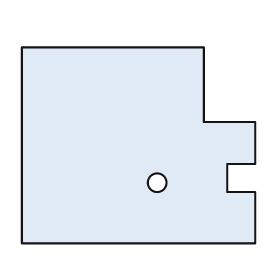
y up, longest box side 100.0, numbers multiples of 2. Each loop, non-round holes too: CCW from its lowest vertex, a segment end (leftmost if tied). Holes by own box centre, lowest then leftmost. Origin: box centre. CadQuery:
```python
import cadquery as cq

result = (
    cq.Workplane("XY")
    .moveTo(-50.0, -42.0)
    .lineTo(50.0, -42.0)
    .lineTo(50.0, -20.0)
    .lineTo(38.0, -20.0)
    .lineTo(38.0, -8.0)
    .lineTo(50.0, -8.0)
    .lineTo(50.0, 10.0)
    .lineTo(28.0, 10.0)
    .lineTo(28.0, 42.0)
    .lineTo(-50.0, 42.0)
    .close()
    .moveTo(8.0, -16.0)
    .circle(4.0)
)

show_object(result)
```